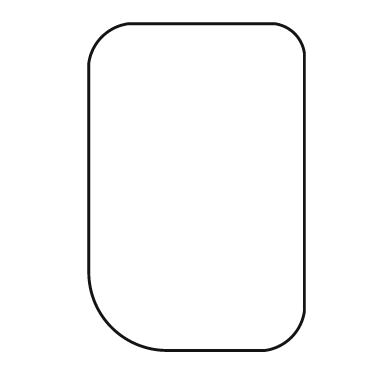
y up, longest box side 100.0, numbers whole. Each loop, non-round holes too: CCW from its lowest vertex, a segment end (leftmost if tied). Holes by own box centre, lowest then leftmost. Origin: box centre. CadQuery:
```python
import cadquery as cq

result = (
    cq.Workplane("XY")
    .moveTo(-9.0, -50.0)
    .lineTo(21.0, -50.0)
    .threePointArc((29.0, -46.0), (33.0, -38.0))
    .lineTo(33.0, 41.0)
    .threePointArc((30.0, 47.0), (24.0, 50.0))
    .lineTo(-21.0, 50.0)
    .threePointArc((-29.0, 46.0), (-33.0, 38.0))
    .lineTo(-33.0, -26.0)
    .threePointArc((-26.0, -43.0), (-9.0, -50.0))
    .close()
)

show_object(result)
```